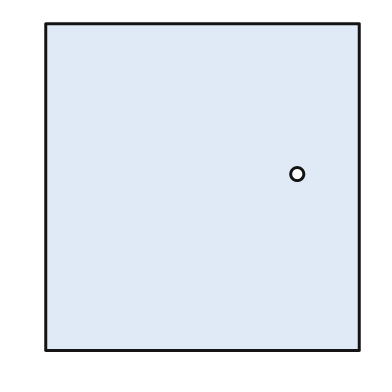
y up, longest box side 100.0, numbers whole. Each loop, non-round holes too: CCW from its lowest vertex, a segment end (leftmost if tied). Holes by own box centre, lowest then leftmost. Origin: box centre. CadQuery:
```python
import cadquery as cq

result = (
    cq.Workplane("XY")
    .moveTo(-48.0, -50.0)
    .lineTo(48.0, -50.0)
    .lineTo(48.0, 50.0)
    .lineTo(-48.0, 50.0)
    .close()
    .moveTo(29.0, 4.0)
    .circle(2.0)
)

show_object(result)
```